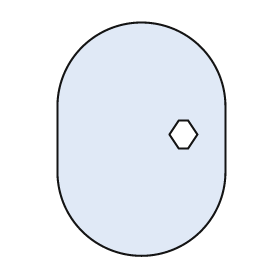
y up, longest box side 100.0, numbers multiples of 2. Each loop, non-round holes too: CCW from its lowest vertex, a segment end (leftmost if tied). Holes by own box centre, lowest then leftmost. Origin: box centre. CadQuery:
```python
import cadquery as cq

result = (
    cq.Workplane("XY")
    .moveTo(-36.0, -14.0)
    .threePointArc((0.0, -50.0), (36.0, -14.0))
    .lineTo(36.0, 14.0)
    .threePointArc((0.0, 50.0), (-36.0, 14.0))
    .close()
    .moveTo(16.0, -4.0)
    .lineTo(20.0, -4.0)
    .lineTo(24.0, 2.0)
    .lineTo(20.0, 8.0)
    .lineTo(16.0, 8.0)
    .lineTo(12.0, 2.0)
    .close()
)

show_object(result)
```